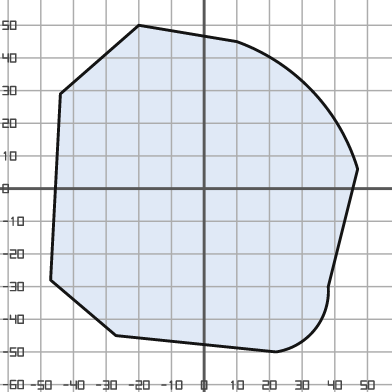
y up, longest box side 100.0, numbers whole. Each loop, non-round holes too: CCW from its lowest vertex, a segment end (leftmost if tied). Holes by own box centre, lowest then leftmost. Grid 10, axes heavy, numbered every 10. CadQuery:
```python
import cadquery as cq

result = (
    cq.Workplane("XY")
    .moveTo(22.0, -50.0)
    .threePointArc((34.0, -43.0), (38.0, -30.0))
    .lineTo(47.0, 6.0)
    .threePointArc((33.0, 30.0), (10.0, 45.0))
    .lineTo(-20.0, 50.0)
    .lineTo(-44.0, 29.0)
    .lineTo(-47.0, -28.0)
    .lineTo(-27.0, -45.0)
    .close()
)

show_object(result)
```